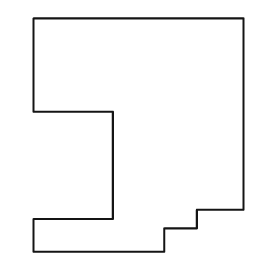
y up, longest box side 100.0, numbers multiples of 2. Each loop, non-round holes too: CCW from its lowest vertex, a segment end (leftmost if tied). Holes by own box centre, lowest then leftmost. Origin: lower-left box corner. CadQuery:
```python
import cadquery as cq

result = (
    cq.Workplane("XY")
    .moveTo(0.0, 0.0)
    .lineTo(56.0, 0.0)
    .lineTo(56.0, 10.0)
    .lineTo(70.0, 10.0)
    .lineTo(70.0, 18.0)
    .lineTo(90.0, 18.0)
    .lineTo(90.0, 100.0)
    .lineTo(0.0, 100.0)
    .lineTo(0.0, 60.0)
    .lineTo(34.0, 60.0)
    .lineTo(34.0, 14.0)
    .lineTo(0.0, 14.0)
    .close()
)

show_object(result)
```